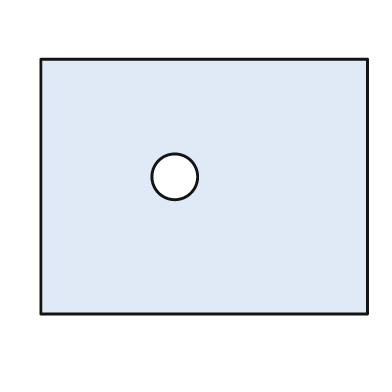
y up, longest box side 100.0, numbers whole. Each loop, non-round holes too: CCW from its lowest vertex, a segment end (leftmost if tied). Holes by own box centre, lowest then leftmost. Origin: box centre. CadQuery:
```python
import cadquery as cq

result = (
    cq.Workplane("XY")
    .moveTo(-50.0, -39.0)
    .lineTo(50.0, -39.0)
    .lineTo(50.0, 39.0)
    .lineTo(-50.0, 39.0)
    .close()
    .moveTo(-9.0, 3.0)
    .circle(7.0)
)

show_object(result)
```